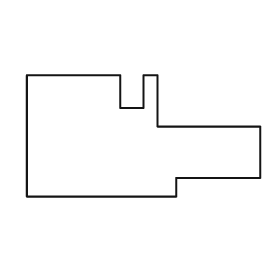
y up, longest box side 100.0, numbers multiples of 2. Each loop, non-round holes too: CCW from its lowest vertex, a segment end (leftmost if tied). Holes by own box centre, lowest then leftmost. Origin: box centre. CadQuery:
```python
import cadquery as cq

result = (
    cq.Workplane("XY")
    .moveTo(-50.0, -26.0)
    .lineTo(14.0, -26.0)
    .lineTo(14.0, -18.0)
    .lineTo(50.0, -18.0)
    .lineTo(50.0, 4.0)
    .lineTo(6.0, 4.0)
    .lineTo(6.0, 26.0)
    .lineTo(0.0, 26.0)
    .lineTo(0.0, 12.0)
    .lineTo(-10.0, 12.0)
    .lineTo(-10.0, 26.0)
    .lineTo(-50.0, 26.0)
    .close()
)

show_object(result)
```